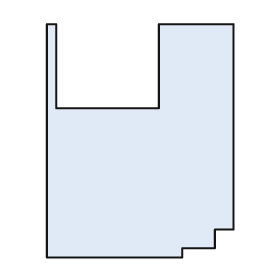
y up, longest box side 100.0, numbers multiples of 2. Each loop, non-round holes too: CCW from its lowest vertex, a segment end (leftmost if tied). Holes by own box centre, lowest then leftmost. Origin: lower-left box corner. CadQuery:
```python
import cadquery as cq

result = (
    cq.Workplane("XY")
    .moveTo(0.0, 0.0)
    .lineTo(58.0, 0.0)
    .lineTo(58.0, 4.0)
    .lineTo(72.0, 4.0)
    .lineTo(72.0, 12.0)
    .lineTo(80.0, 12.0)
    .lineTo(80.0, 100.0)
    .lineTo(48.0, 100.0)
    .lineTo(48.0, 64.0)
    .lineTo(4.0, 64.0)
    .lineTo(4.0, 100.0)
    .lineTo(0.0, 100.0)
    .close()
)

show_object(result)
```